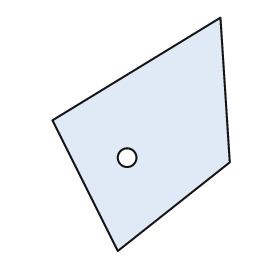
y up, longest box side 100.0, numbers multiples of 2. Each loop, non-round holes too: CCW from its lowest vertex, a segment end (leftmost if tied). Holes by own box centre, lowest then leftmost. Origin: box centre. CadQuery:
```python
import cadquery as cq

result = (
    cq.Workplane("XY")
    .moveTo(-10.0, -50.0)
    .lineTo(38.0, -12.0)
    .lineTo(34.0, 50.0)
    .lineTo(-38.0, 6.0)
    .close()
    .moveTo(-6.0, -10.0)
    .circle(4.0)
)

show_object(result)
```